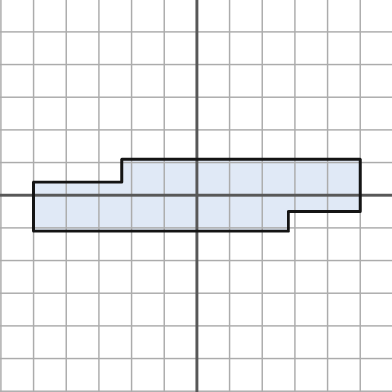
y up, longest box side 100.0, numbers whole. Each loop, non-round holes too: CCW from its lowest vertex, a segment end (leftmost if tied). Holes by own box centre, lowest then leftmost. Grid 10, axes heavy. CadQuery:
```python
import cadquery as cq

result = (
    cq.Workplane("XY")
    .moveTo(-50.0, -11.0)
    .lineTo(28.0, -11.0)
    .lineTo(28.0, -5.0)
    .lineTo(50.0, -5.0)
    .lineTo(50.0, 11.0)
    .lineTo(-23.0, 11.0)
    .lineTo(-23.0, 4.0)
    .lineTo(-50.0, 4.0)
    .close()
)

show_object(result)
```